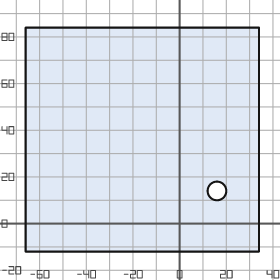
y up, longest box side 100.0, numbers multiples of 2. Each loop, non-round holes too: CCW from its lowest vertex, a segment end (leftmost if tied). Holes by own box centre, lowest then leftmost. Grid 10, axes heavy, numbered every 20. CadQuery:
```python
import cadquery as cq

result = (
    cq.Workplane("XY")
    .moveTo(-66.0, -12.0)
    .lineTo(34.0, -12.0)
    .lineTo(34.0, 84.0)
    .lineTo(-66.0, 84.0)
    .close()
    .moveTo(16.0, 14.0)
    .circle(4.0)
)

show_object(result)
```